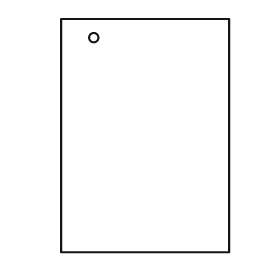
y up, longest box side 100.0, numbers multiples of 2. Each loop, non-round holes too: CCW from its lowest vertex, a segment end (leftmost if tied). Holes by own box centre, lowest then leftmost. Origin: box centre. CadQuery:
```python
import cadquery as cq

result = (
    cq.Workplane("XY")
    .moveTo(-36.0, -50.0)
    .lineTo(36.0, -50.0)
    .lineTo(36.0, 50.0)
    .lineTo(-36.0, 50.0)
    .close()
    .moveTo(-22.0, 42.0)
    .circle(2.0)
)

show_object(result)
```